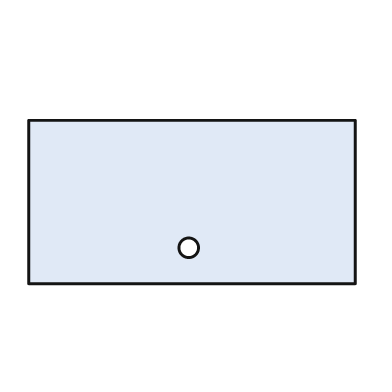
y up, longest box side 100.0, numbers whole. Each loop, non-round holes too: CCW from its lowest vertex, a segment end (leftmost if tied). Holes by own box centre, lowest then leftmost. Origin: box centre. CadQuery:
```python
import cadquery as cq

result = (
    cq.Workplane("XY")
    .moveTo(-50.0, -25.0)
    .lineTo(50.0, -25.0)
    .lineTo(50.0, 25.0)
    .lineTo(-50.0, 25.0)
    .close()
    .moveTo(-1.0, -14.0)
    .circle(3.0)
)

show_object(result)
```